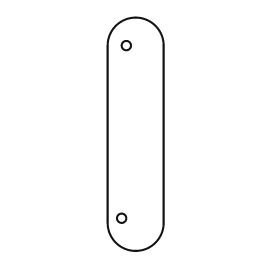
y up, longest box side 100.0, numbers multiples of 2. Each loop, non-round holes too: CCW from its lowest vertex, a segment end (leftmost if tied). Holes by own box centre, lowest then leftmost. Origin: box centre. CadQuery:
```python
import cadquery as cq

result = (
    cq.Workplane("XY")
    .moveTo(-12.0, -38.0)
    .threePointArc((0.0, -50.0), (12.0, -38.0))
    .lineTo(12.0, 38.0)
    .threePointArc((0.0, 50.0), (-12.0, 38.0))
    .close()
    .moveTo(-6.0, -36.0)
    .circle(2.0)
    .moveTo(-4.0, 38.0)
    .circle(2.0)
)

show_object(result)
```